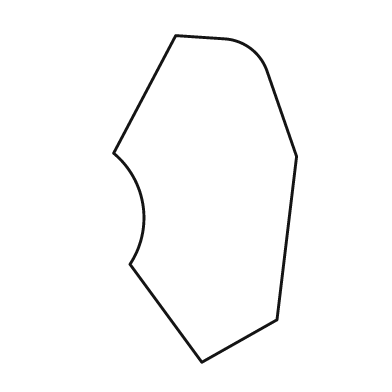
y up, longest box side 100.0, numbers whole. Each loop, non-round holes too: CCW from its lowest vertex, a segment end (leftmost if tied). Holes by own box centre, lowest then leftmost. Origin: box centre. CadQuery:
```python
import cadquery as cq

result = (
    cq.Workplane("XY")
    .moveTo(-1.0, -50.0)
    .lineTo(22.0, -37.0)
    .lineTo(28.0, 13.0)
    .lineTo(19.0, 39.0)
    .threePointArc((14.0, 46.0), (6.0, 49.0))
    .lineTo(-9.0, 50.0)
    .lineTo(-28.0, 14.0)
    .threePointArc((-19.0, -2.0), (-23.0, -20.0))
    .close()
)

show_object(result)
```